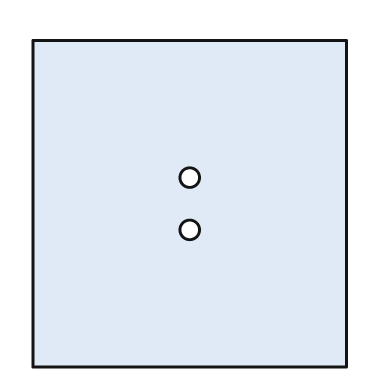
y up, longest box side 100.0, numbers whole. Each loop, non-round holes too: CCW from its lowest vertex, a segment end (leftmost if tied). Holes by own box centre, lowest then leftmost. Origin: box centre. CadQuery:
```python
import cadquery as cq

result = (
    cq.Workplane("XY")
    .moveTo(-48.0, -50.0)
    .lineTo(48.0, -50.0)
    .lineTo(48.0, 50.0)
    .lineTo(-48.0, 50.0)
    .close()
    .moveTo(0.0, -8.0)
    .circle(3.0)
    .moveTo(0.0, 8.0)
    .circle(3.0)
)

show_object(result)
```